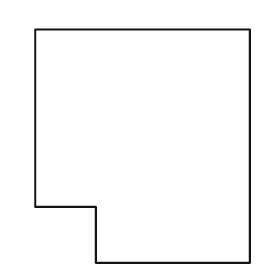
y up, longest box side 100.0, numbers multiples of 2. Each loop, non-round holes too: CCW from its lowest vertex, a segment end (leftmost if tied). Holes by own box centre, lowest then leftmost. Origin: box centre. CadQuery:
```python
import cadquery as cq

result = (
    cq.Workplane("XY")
    .moveTo(-20.0, -50.0)
    .lineTo(46.0, -50.0)
    .lineTo(46.0, 50.0)
    .lineTo(-46.0, 50.0)
    .lineTo(-46.0, -26.0)
    .lineTo(-20.0, -26.0)
    .close()
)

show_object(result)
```